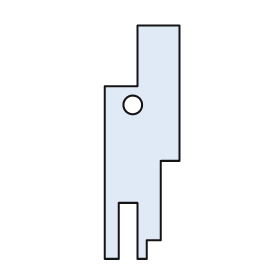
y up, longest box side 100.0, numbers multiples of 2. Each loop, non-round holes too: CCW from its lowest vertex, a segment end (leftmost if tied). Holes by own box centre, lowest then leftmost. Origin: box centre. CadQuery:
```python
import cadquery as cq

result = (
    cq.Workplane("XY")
    .moveTo(-16.0, -50.0)
    .lineTo(-10.0, -50.0)
    .lineTo(-10.0, -26.0)
    .lineTo(-2.0, -26.0)
    .lineTo(-2.0, -50.0)
    .lineTo(2.0, -50.0)
    .lineTo(2.0, -42.0)
    .lineTo(8.0, -42.0)
    .lineTo(8.0, -8.0)
    .lineTo(16.0, -8.0)
    .lineTo(16.0, 50.0)
    .lineTo(-2.0, 50.0)
    .lineTo(-2.0, 24.0)
    .lineTo(-16.0, 24.0)
    .close()
    .moveTo(-4.0, 16.0)
    .circle(4.0)
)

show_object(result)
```